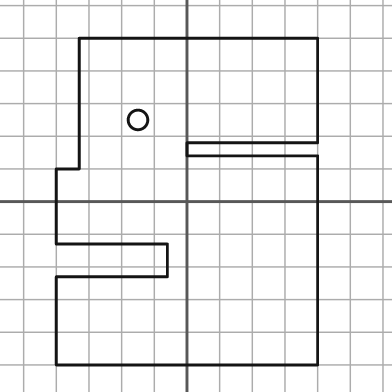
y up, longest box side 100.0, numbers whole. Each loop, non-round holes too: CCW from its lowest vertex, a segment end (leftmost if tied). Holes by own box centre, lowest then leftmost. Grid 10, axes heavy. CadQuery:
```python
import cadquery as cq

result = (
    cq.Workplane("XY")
    .moveTo(-40.0, -50.0)
    .lineTo(40.0, -50.0)
    .lineTo(40.0, 14.0)
    .lineTo(0.0, 14.0)
    .lineTo(0.0, 18.0)
    .lineTo(40.0, 18.0)
    .lineTo(40.0, 50.0)
    .lineTo(-33.0, 50.0)
    .lineTo(-33.0, 10.0)
    .lineTo(-40.0, 10.0)
    .lineTo(-40.0, -13.0)
    .lineTo(-6.0, -13.0)
    .lineTo(-6.0, -23.0)
    .lineTo(-40.0, -23.0)
    .close()
    .moveTo(-15.0, 25.0)
    .circle(3.0)
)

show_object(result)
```